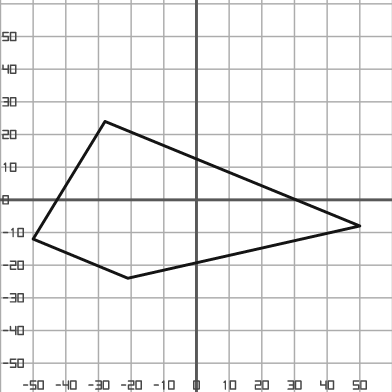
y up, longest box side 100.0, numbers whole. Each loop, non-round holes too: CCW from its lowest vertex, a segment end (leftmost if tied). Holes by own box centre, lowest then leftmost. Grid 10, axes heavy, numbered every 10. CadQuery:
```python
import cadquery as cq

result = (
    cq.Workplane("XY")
    .moveTo(-21.0, -24.0)
    .lineTo(50.0, -8.0)
    .lineTo(-28.0, 24.0)
    .lineTo(-50.0, -12.0)
    .close()
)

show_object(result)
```